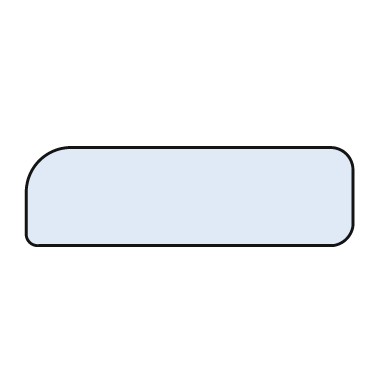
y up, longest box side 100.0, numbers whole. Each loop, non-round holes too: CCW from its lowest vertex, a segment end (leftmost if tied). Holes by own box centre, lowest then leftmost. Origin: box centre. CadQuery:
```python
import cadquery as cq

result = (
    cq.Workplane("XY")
    .moveTo(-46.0, -15.0)
    .lineTo(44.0, -15.0)
    .threePointArc((48.0, -13.0), (50.0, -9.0))
    .lineTo(50.0, 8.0)
    .threePointArc((48.0, 13.0), (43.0, 15.0))
    .lineTo(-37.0, 15.0)
    .threePointArc((-46.0, 11.0), (-50.0, 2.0))
    .lineTo(-50.0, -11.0)
    .threePointArc((-49.0, -14.0), (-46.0, -15.0))
    .close()
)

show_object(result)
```